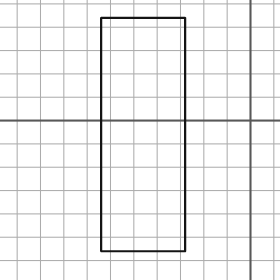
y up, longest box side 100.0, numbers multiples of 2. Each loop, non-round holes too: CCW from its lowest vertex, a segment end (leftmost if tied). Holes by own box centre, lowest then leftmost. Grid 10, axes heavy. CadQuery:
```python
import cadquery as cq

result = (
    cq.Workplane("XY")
    .moveTo(-64.0, -56.0)
    .lineTo(-28.0, -56.0)
    .lineTo(-28.0, 44.0)
    .lineTo(-64.0, 44.0)
    .close()
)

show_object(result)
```